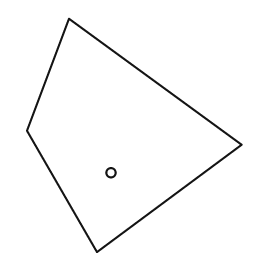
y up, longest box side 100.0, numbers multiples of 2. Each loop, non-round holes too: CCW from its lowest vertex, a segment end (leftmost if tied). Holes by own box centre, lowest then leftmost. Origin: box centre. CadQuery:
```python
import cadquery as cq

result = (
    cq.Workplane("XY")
    .moveTo(-16.0, -50.0)
    .lineTo(46.0, -4.0)
    .lineTo(-28.0, 50.0)
    .lineTo(-46.0, 2.0)
    .close()
    .moveTo(-10.0, -16.0)
    .circle(2.0)
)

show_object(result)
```